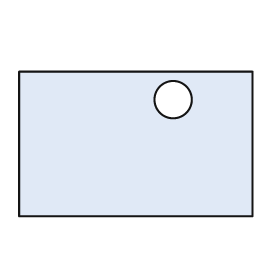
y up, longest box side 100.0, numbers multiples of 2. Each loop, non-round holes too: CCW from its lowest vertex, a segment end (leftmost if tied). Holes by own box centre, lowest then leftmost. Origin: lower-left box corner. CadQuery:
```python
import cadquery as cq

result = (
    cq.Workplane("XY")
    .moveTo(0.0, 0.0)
    .lineTo(100.0, 0.0)
    .lineTo(100.0, 62.0)
    .lineTo(0.0, 62.0)
    .close()
    .moveTo(66.0, 50.0)
    .circle(8.0)
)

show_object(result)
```